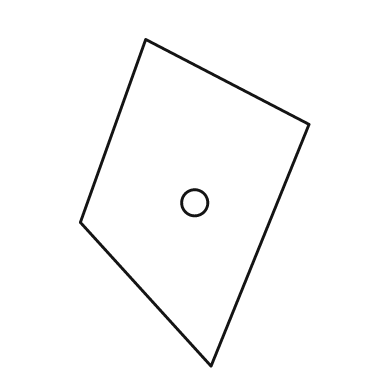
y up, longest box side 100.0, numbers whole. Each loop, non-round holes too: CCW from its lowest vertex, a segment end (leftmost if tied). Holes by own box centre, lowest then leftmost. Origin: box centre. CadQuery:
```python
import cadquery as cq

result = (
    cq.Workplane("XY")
    .moveTo(5.0, -50.0)
    .lineTo(35.0, 24.0)
    .lineTo(-15.0, 50.0)
    .lineTo(-35.0, -6.0)
    .close()
    .moveTo(0.0, 0.0)
    .circle(4.0)
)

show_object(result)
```